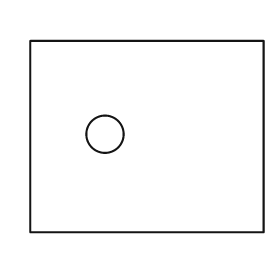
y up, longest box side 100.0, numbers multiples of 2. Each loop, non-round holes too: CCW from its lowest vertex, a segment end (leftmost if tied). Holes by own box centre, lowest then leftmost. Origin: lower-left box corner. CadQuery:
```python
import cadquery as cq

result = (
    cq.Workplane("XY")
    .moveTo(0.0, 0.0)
    .lineTo(100.0, 0.0)
    .lineTo(100.0, 82.0)
    .lineTo(0.0, 82.0)
    .close()
    .moveTo(32.0, 42.0)
    .circle(8.0)
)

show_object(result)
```